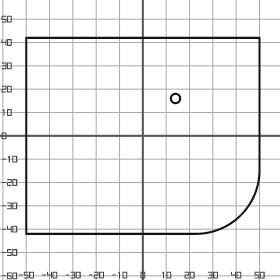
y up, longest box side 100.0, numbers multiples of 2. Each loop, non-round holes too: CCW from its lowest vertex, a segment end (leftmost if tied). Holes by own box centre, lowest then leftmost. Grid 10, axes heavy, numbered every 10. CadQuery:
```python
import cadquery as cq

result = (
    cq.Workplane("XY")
    .moveTo(-50.0, -42.0)
    .lineTo(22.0, -42.0)
    .threePointArc((42.0, -34.0), (50.0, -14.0))
    .lineTo(50.0, 42.0)
    .lineTo(-50.0, 42.0)
    .close()
    .moveTo(14.0, 16.0)
    .circle(2.0)
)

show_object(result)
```